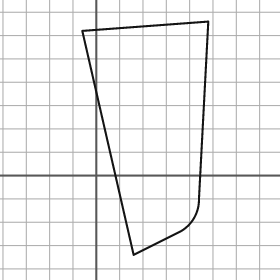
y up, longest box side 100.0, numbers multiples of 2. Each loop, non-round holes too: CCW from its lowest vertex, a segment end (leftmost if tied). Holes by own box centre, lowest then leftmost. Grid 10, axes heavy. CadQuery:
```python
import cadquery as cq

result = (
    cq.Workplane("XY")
    .moveTo(16.0, -34.0)
    .lineTo(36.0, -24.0)
    .threePointArc((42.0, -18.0), (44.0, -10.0))
    .lineTo(48.0, 66.0)
    .lineTo(-6.0, 62.0)
    .close()
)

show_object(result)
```